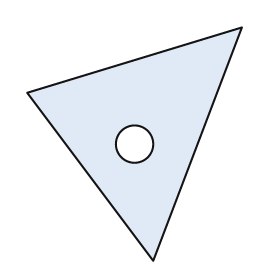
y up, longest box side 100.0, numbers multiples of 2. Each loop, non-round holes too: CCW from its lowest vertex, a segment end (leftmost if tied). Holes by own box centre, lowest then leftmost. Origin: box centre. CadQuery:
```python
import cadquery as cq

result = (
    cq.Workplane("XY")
    .moveTo(8.0, -50.0)
    .lineTo(46.0, 50.0)
    .lineTo(-46.0, 22.0)
    .close()
    .moveTo(0.0, 0.0)
    .circle(8.0)
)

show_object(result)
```